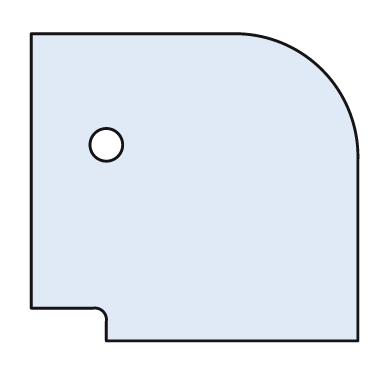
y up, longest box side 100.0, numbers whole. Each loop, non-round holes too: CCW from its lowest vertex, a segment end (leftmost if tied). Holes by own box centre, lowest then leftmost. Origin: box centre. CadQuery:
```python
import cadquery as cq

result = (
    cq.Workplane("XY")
    .moveTo(-27.0, -47.0)
    .lineTo(50.0, -47.0)
    .lineTo(50.0, 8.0)
    .threePointArc((39.0, 36.0), (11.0, 47.0))
    .lineTo(-50.0, 47.0)
    .lineTo(-50.0, -37.0)
    .lineTo(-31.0, -37.0)
    .threePointArc((-28.0, -38.0), (-27.0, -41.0))
    .close()
    .moveTo(-27.0, 13.0)
    .circle(5.0)
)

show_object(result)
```